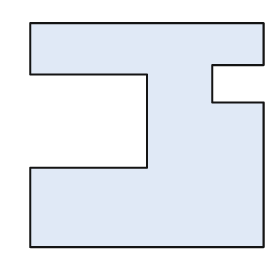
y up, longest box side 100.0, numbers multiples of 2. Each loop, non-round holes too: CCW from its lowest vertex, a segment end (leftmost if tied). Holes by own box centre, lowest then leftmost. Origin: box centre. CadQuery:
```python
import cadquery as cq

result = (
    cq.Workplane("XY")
    .moveTo(-50.0, -48.0)
    .lineTo(50.0, -48.0)
    .lineTo(50.0, 14.0)
    .lineTo(28.0, 14.0)
    .lineTo(28.0, 30.0)
    .lineTo(50.0, 30.0)
    .lineTo(50.0, 48.0)
    .lineTo(-50.0, 48.0)
    .lineTo(-50.0, 26.0)
    .lineTo(0.0, 26.0)
    .lineTo(0.0, -14.0)
    .lineTo(-50.0, -14.0)
    .close()
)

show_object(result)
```